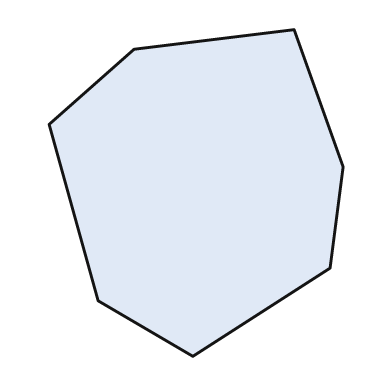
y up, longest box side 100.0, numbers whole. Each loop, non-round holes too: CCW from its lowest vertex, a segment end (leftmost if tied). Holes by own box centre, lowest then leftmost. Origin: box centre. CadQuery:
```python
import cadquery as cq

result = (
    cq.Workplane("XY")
    .moveTo(-1.0, -50.0)
    .lineTo(41.0, -23.0)
    .lineTo(45.0, 8.0)
    .lineTo(30.0, 50.0)
    .lineTo(-19.0, 44.0)
    .lineTo(-45.0, 21.0)
    .lineTo(-30.0, -33.0)
    .close()
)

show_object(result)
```